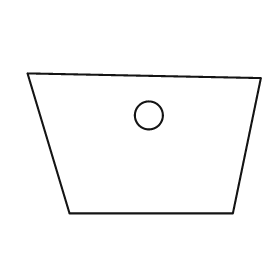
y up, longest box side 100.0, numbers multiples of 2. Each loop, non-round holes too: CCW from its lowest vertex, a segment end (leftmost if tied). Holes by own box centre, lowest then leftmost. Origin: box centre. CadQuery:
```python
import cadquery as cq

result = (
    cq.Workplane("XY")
    .moveTo(-32.0, -30.0)
    .lineTo(38.0, -30.0)
    .lineTo(50.0, 28.0)
    .lineTo(-50.0, 30.0)
    .close()
    .moveTo(2.0, 12.0)
    .circle(6.0)
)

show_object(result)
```